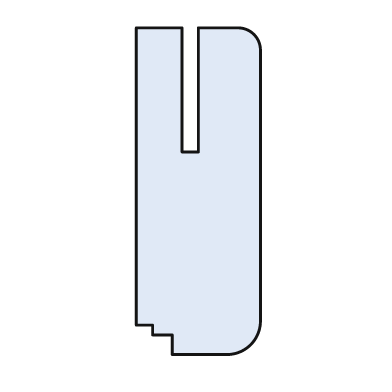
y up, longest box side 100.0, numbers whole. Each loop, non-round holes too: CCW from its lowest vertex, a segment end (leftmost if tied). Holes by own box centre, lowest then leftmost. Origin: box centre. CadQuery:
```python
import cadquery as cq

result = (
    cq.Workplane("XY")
    .moveTo(-8.0, -50.0)
    .lineTo(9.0, -50.0)
    .threePointArc((16.0, -47.0), (19.0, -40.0))
    .lineTo(19.0, 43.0)
    .threePointArc((17.0, 48.0), (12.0, 50.0))
    .lineTo(0.0, 50.0)
    .lineTo(0.0, 12.0)
    .lineTo(-5.0, 12.0)
    .lineTo(-5.0, 50.0)
    .lineTo(-19.0, 50.0)
    .lineTo(-19.0, -41.0)
    .lineTo(-14.0, -41.0)
    .lineTo(-14.0, -44.0)
    .lineTo(-8.0, -44.0)
    .close()
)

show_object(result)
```